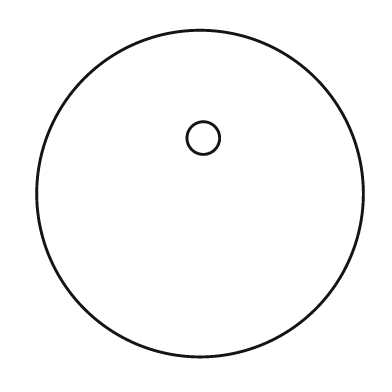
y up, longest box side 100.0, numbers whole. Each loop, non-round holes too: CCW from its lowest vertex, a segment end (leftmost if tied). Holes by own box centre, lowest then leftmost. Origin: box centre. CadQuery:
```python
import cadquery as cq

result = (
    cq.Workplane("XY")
    .moveTo(0.0, 0.0)
    .circle(50.0)
    .moveTo(1.0, 17.0)
    .circle(5.0)
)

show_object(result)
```